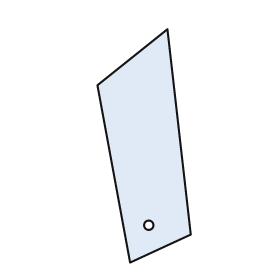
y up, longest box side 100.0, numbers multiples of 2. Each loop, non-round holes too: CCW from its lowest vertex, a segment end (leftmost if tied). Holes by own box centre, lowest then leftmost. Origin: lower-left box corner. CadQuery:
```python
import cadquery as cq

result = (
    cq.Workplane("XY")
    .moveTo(14.0, 0.0)
    .lineTo(40.0, 12.0)
    .lineTo(30.0, 100.0)
    .lineTo(0.0, 76.0)
    .close()
    .moveTo(22.0, 16.0)
    .circle(2.0)
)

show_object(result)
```